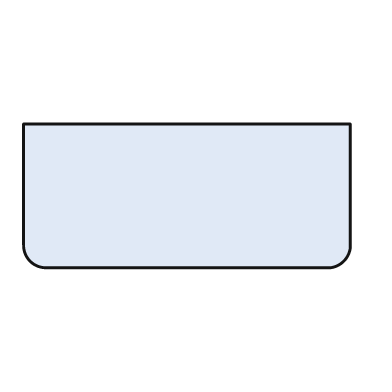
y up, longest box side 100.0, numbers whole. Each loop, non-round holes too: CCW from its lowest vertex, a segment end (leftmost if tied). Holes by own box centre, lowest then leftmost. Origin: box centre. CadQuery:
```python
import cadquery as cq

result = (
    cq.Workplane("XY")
    .moveTo(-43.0, -22.0)
    .lineTo(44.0, -22.0)
    .threePointArc((48.0, -20.0), (50.0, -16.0))
    .lineTo(50.0, 22.0)
    .lineTo(-50.0, 22.0)
    .lineTo(-50.0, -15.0)
    .threePointArc((-48.0, -20.0), (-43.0, -22.0))
    .close()
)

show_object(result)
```